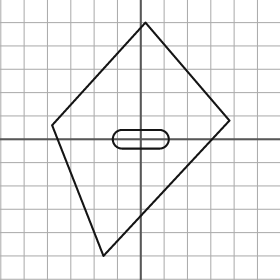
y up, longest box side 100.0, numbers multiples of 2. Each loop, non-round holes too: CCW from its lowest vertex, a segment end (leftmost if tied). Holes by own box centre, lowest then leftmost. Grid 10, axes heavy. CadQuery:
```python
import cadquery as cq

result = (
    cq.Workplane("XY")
    .moveTo(-16.0, -50.0)
    .lineTo(38.0, 8.0)
    .lineTo(2.0, 50.0)
    .lineTo(-38.0, 6.0)
    .close()
    .moveTo(-8.0, -4.0)
    .lineTo(8.0, -4.0)
    .threePointArc((12.0, 0.0), (8.0, 4.0))
    .lineTo(-8.0, 4.0)
    .threePointArc((-12.0, 0.0), (-8.0, -4.0))
    .close()
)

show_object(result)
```